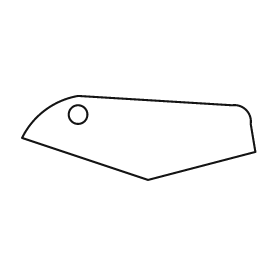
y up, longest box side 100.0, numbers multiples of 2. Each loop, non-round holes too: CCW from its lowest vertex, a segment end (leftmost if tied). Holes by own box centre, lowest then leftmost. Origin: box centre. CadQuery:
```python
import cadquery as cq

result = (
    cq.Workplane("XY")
    .moveTo(4.0, -18.0)
    .lineTo(50.0, -6.0)
    .lineTo(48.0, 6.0)
    .threePointArc((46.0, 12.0), (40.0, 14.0))
    .lineTo(-26.0, 18.0)
    .threePointArc((-40.0, 12.0), (-50.0, 0.0))
    .close()
    .moveTo(-26.0, 10.0)
    .circle(4.0)
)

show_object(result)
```